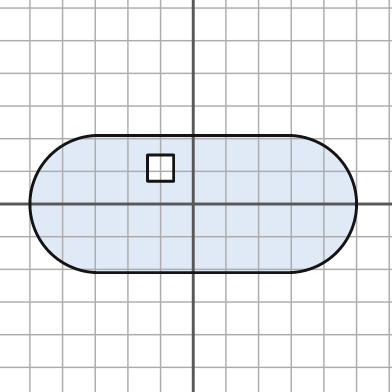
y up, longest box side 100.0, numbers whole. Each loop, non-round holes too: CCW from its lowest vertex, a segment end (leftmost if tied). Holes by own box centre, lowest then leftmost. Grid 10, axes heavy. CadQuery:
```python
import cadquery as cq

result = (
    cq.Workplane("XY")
    .moveTo(-29.0, -21.0)
    .lineTo(29.0, -21.0)
    .threePointArc((50.0, 0.0), (29.0, 21.0))
    .lineTo(-29.0, 21.0)
    .threePointArc((-50.0, 0.0), (-29.0, -21.0))
    .close()
    .moveTo(-14.0, 7.0)
    .lineTo(-6.0, 7.0)
    .lineTo(-6.0, 15.0)
    .lineTo(-14.0, 15.0)
    .close()
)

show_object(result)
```